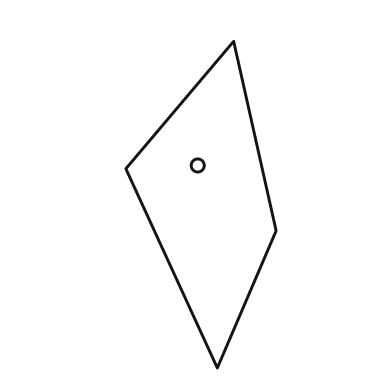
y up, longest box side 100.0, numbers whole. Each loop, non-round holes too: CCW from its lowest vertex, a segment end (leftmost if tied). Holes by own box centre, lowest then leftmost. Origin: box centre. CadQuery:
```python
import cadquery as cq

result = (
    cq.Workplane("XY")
    .moveTo(5.0, -50.0)
    .lineTo(23.0, -8.0)
    .lineTo(10.0, 50.0)
    .lineTo(-23.0, 11.0)
    .close()
    .moveTo(-1.0, 12.0)
    .circle(2.0)
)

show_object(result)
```